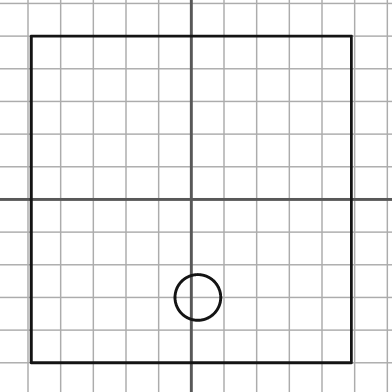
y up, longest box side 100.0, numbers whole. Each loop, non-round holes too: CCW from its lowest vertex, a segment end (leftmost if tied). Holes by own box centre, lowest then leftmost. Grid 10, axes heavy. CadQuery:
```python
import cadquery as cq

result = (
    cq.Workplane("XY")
    .moveTo(-49.0, -50.0)
    .lineTo(49.0, -50.0)
    .lineTo(49.0, 50.0)
    .lineTo(-49.0, 50.0)
    .close()
    .moveTo(2.0, -30.0)
    .circle(7.0)
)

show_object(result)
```